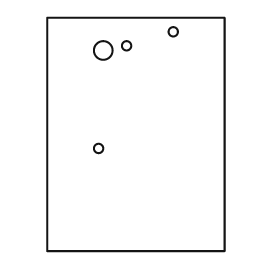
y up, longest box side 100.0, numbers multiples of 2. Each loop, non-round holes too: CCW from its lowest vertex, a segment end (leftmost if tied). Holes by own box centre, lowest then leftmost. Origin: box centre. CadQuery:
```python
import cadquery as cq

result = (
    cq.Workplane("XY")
    .moveTo(-38.0, -50.0)
    .lineTo(38.0, -50.0)
    .lineTo(38.0, 50.0)
    .lineTo(-38.0, 50.0)
    .close()
    .moveTo(-16.0, -6.0)
    .circle(2.0)
    .moveTo(-14.0, 36.0)
    .circle(4.0)
    .moveTo(-4.0, 38.0)
    .circle(2.0)
    .moveTo(16.0, 44.0)
    .circle(2.0)
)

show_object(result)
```